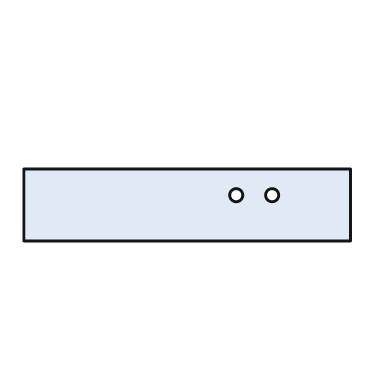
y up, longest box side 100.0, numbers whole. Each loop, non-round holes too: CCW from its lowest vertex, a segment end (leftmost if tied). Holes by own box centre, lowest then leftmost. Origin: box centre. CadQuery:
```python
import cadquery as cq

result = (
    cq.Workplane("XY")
    .moveTo(-50.0, -11.0)
    .lineTo(50.0, -11.0)
    .lineTo(50.0, 11.0)
    .lineTo(-50.0, 11.0)
    .close()
    .moveTo(15.0, 3.0)
    .circle(2.0)
    .moveTo(26.0, 3.0)
    .circle(2.0)
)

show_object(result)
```